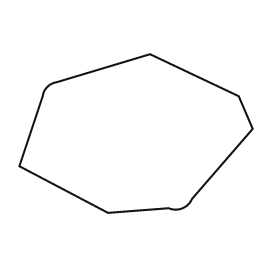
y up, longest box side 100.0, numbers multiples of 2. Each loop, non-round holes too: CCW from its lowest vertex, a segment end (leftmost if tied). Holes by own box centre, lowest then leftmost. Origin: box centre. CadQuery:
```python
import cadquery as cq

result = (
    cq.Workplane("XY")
    .moveTo(-12.0, -34.0)
    .lineTo(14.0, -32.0)
    .threePointArc((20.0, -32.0), (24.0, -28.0))
    .lineTo(50.0, 2.0)
    .lineTo(44.0, 16.0)
    .lineTo(6.0, 34.0)
    .lineTo(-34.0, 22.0)
    .threePointArc((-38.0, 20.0), (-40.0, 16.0))
    .lineTo(-50.0, -14.0)
    .close()
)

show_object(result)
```